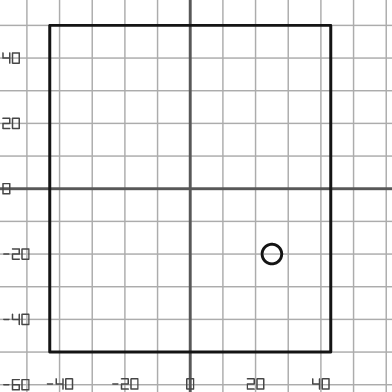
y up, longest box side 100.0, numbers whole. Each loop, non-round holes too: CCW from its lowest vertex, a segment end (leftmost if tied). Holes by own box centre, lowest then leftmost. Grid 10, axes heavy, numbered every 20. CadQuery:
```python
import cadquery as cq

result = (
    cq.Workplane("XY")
    .moveTo(-43.0, -50.0)
    .lineTo(43.0, -50.0)
    .lineTo(43.0, 50.0)
    .lineTo(-43.0, 50.0)
    .close()
    .moveTo(25.0, -20.0)
    .circle(3.0)
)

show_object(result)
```